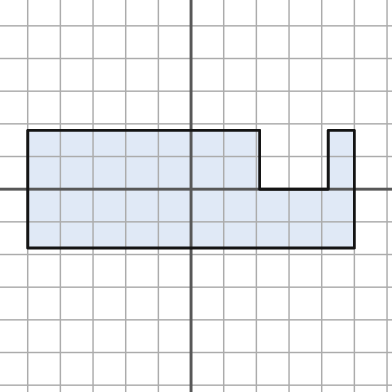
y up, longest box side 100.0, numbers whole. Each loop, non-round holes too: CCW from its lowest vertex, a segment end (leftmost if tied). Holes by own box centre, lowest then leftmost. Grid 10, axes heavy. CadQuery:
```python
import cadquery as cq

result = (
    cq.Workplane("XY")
    .moveTo(-50.0, -18.0)
    .lineTo(50.0, -18.0)
    .lineTo(50.0, 18.0)
    .lineTo(42.0, 18.0)
    .lineTo(42.0, 0.0)
    .lineTo(21.0, 0.0)
    .lineTo(21.0, 18.0)
    .lineTo(-50.0, 18.0)
    .close()
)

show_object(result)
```